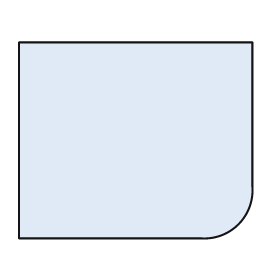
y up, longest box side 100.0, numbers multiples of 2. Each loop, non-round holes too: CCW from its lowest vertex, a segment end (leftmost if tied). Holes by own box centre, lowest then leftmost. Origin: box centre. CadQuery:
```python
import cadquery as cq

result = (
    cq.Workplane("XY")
    .moveTo(-50.0, -42.0)
    .lineTo(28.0, -42.0)
    .threePointArc((44.0, -36.0), (50.0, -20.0))
    .lineTo(50.0, 42.0)
    .lineTo(-50.0, 42.0)
    .close()
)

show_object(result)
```